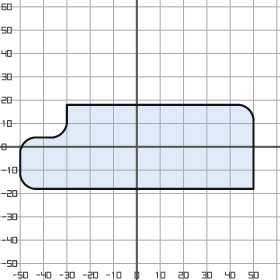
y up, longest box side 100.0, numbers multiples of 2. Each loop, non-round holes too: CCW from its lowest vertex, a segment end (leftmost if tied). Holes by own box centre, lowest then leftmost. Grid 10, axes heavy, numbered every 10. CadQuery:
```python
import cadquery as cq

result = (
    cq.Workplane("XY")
    .moveTo(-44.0, -18.0)
    .lineTo(50.0, -18.0)
    .lineTo(50.0, 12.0)
    .threePointArc((48.0, 16.0), (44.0, 18.0))
    .lineTo(-30.0, 18.0)
    .lineTo(-30.0, 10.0)
    .threePointArc((-32.0, 6.0), (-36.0, 4.0))
    .lineTo(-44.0, 4.0)
    .threePointArc((-48.0, 2.0), (-50.0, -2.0))
    .lineTo(-50.0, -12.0)
    .threePointArc((-48.0, -16.0), (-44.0, -18.0))
    .close()
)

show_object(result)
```